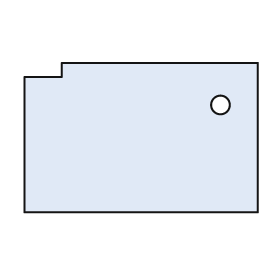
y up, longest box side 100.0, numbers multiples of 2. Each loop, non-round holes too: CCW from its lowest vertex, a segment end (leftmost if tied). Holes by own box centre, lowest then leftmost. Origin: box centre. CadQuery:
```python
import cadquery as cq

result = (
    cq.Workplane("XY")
    .moveTo(-50.0, -32.0)
    .lineTo(50.0, -32.0)
    .lineTo(50.0, 32.0)
    .lineTo(-34.0, 32.0)
    .lineTo(-34.0, 26.0)
    .lineTo(-50.0, 26.0)
    .close()
    .moveTo(34.0, 14.0)
    .circle(4.0)
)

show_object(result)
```